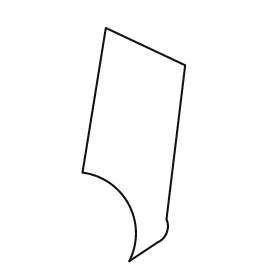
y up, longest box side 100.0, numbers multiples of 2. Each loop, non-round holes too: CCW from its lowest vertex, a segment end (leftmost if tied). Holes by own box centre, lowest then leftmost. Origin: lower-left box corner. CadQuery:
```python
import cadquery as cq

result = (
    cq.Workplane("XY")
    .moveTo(20.0, 0.0)
    .lineTo(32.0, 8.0)
    .threePointArc((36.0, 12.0), (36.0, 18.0))
    .lineTo(44.0, 84.0)
    .lineTo(10.0, 100.0)
    .lineTo(0.0, 38.0)
    .threePointArc((20.0, 24.0), (20.0, 0.0))
    .close()
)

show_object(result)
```